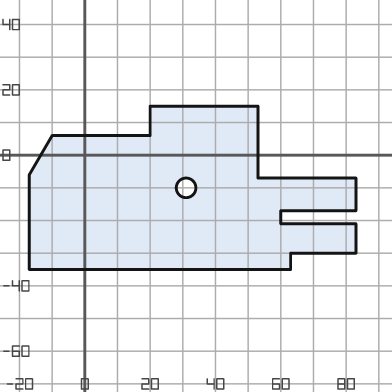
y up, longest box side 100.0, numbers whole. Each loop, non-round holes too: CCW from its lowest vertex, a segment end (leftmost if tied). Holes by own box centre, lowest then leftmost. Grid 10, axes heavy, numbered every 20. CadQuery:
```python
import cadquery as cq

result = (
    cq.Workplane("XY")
    .moveTo(-17.0, -35.0)
    .lineTo(63.0, -35.0)
    .lineTo(63.0, -30.0)
    .lineTo(83.0, -30.0)
    .lineTo(83.0, -21.0)
    .lineTo(60.0, -21.0)
    .lineTo(60.0, -17.0)
    .lineTo(83.0, -17.0)
    .lineTo(83.0, -7.0)
    .lineTo(53.0, -7.0)
    .lineTo(53.0, 15.0)
    .lineTo(20.0, 15.0)
    .lineTo(20.0, 6.0)
    .lineTo(-10.0, 6.0)
    .lineTo(-17.0, -6.0)
    .close()
    .moveTo(31.0, -10.0)
    .circle(3.0)
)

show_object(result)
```